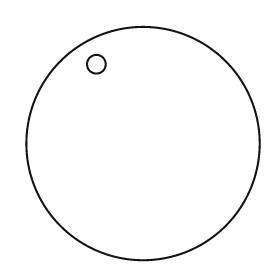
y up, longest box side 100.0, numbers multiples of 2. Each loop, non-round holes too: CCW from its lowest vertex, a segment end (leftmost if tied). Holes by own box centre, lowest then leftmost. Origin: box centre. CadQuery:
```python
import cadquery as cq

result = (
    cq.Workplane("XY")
    .moveTo(0.0, 0.0)
    .circle(50.0)
    .moveTo(-20.0, 34.0)
    .circle(4.0)
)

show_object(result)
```